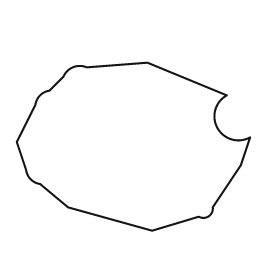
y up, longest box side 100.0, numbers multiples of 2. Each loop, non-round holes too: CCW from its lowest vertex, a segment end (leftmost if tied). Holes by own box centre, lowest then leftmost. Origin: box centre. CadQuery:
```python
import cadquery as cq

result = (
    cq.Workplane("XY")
    .moveTo(8.0, -36.0)
    .lineTo(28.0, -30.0)
    .threePointArc((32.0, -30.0), (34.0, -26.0))
    .lineTo(46.0, -8.0)
    .lineTo(50.0, 4.0)
    .threePointArc((36.0, 8.0), (40.0, 22.0))
    .lineTo(6.0, 36.0)
    .lineTo(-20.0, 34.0)
    .threePointArc((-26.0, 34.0), (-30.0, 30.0))
    .lineTo(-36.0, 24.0)
    .threePointArc((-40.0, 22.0), (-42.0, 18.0))
    .lineTo(-50.0, 2.0)
    .lineTo(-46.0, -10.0)
    .threePointArc((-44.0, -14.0), (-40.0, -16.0))
    .lineTo(-28.0, -26.0)
    .close()
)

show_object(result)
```